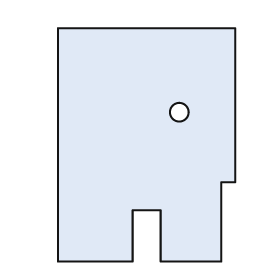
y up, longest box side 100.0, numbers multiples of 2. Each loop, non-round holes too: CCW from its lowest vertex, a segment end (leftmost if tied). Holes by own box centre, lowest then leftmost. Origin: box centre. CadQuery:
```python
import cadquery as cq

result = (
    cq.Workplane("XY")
    .moveTo(-38.0, -50.0)
    .lineTo(-6.0, -50.0)
    .lineTo(-6.0, -28.0)
    .lineTo(6.0, -28.0)
    .lineTo(6.0, -50.0)
    .lineTo(32.0, -50.0)
    .lineTo(32.0, -16.0)
    .lineTo(38.0, -16.0)
    .lineTo(38.0, 50.0)
    .lineTo(-38.0, 50.0)
    .close()
    .moveTo(14.0, 14.0)
    .circle(4.0)
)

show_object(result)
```